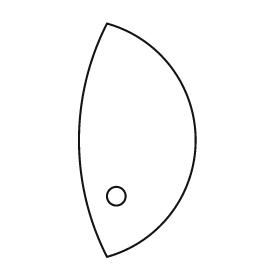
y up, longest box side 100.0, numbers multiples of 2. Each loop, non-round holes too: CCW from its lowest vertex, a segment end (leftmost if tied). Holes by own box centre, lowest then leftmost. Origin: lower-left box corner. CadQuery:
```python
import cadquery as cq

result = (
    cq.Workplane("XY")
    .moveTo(12.0, 0.0)
    .threePointArc((50.0, 50.0), (12.0, 100.0))
    .threePointArc((0.0, 50.0), (12.0, 0.0))
    .close()
    .moveTo(16.0, 26.0)
    .circle(4.0)
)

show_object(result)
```